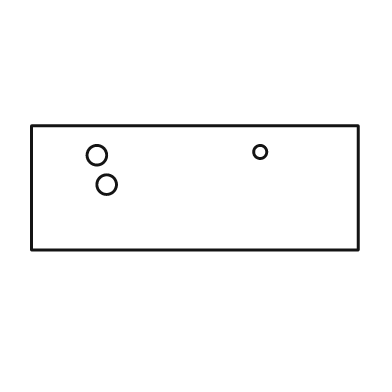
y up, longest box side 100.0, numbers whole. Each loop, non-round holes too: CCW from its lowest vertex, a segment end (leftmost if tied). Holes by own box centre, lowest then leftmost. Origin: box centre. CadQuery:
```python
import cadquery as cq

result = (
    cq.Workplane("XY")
    .moveTo(-50.0, -19.0)
    .lineTo(50.0, -19.0)
    .lineTo(50.0, 19.0)
    .lineTo(-50.0, 19.0)
    .close()
    .moveTo(-27.0, 1.0)
    .circle(3.0)
    .moveTo(-30.0, 10.0)
    .circle(3.0)
    .moveTo(20.0, 11.0)
    .circle(2.0)
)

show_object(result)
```